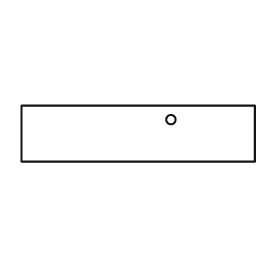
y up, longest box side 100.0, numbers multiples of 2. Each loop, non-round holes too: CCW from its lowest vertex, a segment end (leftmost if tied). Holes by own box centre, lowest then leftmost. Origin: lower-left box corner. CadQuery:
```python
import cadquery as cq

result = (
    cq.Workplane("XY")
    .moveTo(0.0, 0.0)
    .lineTo(100.0, 0.0)
    .lineTo(100.0, 24.0)
    .lineTo(0.0, 24.0)
    .close()
    .moveTo(64.0, 18.0)
    .circle(2.0)
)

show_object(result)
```